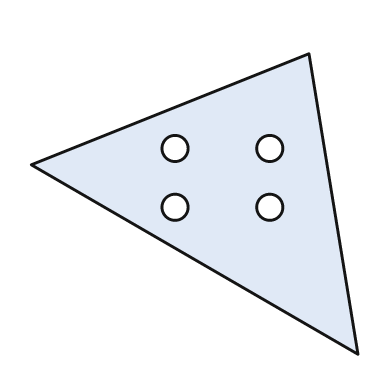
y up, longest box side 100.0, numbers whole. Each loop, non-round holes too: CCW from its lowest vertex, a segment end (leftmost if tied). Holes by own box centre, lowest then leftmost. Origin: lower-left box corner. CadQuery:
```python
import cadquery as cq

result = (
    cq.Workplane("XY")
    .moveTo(100.0, 0.0)
    .lineTo(85.0, 92.0)
    .lineTo(0.0, 58.0)
    .close()
    .moveTo(44.0, 45.0)
    .circle(4.0)
    .moveTo(73.0, 45.0)
    .circle(4.0)
    .moveTo(44.0, 63.0)
    .circle(4.0)
    .moveTo(73.0, 63.0)
    .circle(4.0)
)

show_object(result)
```